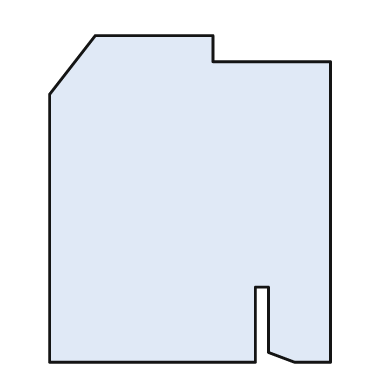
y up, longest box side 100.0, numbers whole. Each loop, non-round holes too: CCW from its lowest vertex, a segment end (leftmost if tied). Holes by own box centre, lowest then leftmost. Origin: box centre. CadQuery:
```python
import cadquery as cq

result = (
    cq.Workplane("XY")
    .moveTo(-43.0, -50.0)
    .lineTo(20.0, -50.0)
    .lineTo(20.0, -27.0)
    .lineTo(24.0, -27.0)
    .lineTo(24.0, -47.0)
    .lineTo(32.0, -50.0)
    .lineTo(43.0, -50.0)
    .lineTo(43.0, 42.0)
    .lineTo(7.0, 42.0)
    .lineTo(7.0, 50.0)
    .lineTo(-29.0, 50.0)
    .lineTo(-43.0, 32.0)
    .close()
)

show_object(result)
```